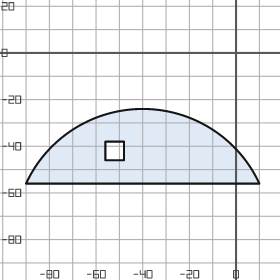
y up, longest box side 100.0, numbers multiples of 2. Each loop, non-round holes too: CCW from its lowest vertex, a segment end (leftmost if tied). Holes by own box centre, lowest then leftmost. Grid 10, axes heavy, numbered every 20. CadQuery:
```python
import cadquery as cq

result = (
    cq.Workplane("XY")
    .moveTo(-90.0, -56.0)
    .lineTo(10.0, -56.0)
    .threePointArc((-40.0, -24.0), (-90.0, -56.0))
    .close()
    .moveTo(-56.0, -46.0)
    .lineTo(-48.0, -46.0)
    .lineTo(-48.0, -38.0)
    .lineTo(-56.0, -38.0)
    .close()
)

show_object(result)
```